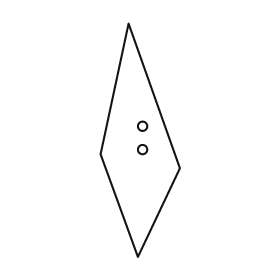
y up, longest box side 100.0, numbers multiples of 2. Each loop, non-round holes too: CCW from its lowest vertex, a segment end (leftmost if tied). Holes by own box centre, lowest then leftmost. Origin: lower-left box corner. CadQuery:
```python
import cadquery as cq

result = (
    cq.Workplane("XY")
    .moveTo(16.0, 0.0)
    .lineTo(34.0, 38.0)
    .lineTo(12.0, 100.0)
    .lineTo(0.0, 44.0)
    .close()
    .moveTo(18.0, 46.0)
    .circle(2.0)
    .moveTo(18.0, 56.0)
    .circle(2.0)
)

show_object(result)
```